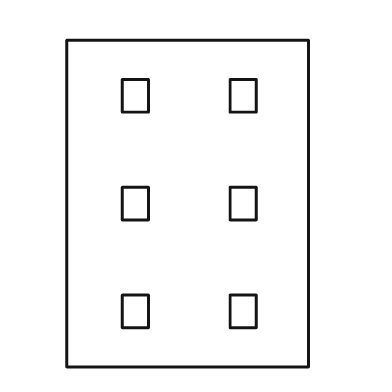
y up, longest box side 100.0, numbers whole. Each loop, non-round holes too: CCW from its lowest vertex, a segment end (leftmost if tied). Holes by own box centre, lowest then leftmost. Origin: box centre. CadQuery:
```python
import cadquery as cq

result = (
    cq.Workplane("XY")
    .moveTo(-37.0, -50.0)
    .lineTo(37.0, -50.0)
    .lineTo(37.0, 50.0)
    .lineTo(-37.0, 50.0)
    .close()
    .moveTo(-20.0, -38.0)
    .lineTo(-12.0, -38.0)
    .lineTo(-12.0, -28.0)
    .lineTo(-20.0, -28.0)
    .close()
    .moveTo(13.0, -38.0)
    .lineTo(21.0, -38.0)
    .lineTo(21.0, -28.0)
    .lineTo(13.0, -28.0)
    .close()
    .moveTo(-20.0, -5.0)
    .lineTo(-12.0, -5.0)
    .lineTo(-12.0, 5.0)
    .lineTo(-20.0, 5.0)
    .close()
    .moveTo(13.0, -5.0)
    .lineTo(21.0, -5.0)
    .lineTo(21.0, 5.0)
    .lineTo(13.0, 5.0)
    .close()
    .moveTo(-20.0, 28.0)
    .lineTo(-12.0, 28.0)
    .lineTo(-12.0, 38.0)
    .lineTo(-20.0, 38.0)
    .close()
    .moveTo(13.0, 28.0)
    .lineTo(21.0, 28.0)
    .lineTo(21.0, 38.0)
    .lineTo(13.0, 38.0)
    .close()
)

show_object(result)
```